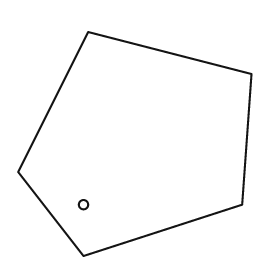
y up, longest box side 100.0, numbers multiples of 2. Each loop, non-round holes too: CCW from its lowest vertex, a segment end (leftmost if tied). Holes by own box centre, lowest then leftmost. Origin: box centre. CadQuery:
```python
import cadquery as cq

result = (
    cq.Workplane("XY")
    .moveTo(-22.0, -48.0)
    .lineTo(46.0, -26.0)
    .lineTo(50.0, 30.0)
    .lineTo(-20.0, 48.0)
    .lineTo(-50.0, -12.0)
    .close()
    .moveTo(-22.0, -26.0)
    .circle(2.0)
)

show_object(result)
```